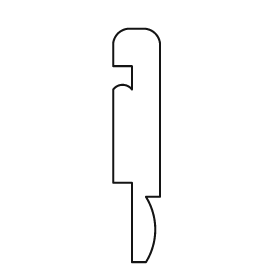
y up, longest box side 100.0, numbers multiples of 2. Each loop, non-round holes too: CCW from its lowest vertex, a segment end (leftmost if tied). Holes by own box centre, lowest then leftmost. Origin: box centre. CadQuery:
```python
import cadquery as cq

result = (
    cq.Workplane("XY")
    .moveTo(-2.0, -50.0)
    .lineTo(4.0, -50.0)
    .threePointArc((8.0, -36.0), (4.0, -22.0))
    .lineTo(10.0, -22.0)
    .lineTo(10.0, 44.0)
    .threePointArc((8.0, 48.0), (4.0, 50.0))
    .lineTo(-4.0, 50.0)
    .threePointArc((-8.0, 48.0), (-10.0, 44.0))
    .lineTo(-10.0, 34.0)
    .lineTo(-2.0, 34.0)
    .lineTo(-2.0, 24.0)
    .threePointArc((-6.0, 26.0), (-10.0, 24.0))
    .lineTo(-10.0, -16.0)
    .lineTo(-2.0, -16.0)
    .close()
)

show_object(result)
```